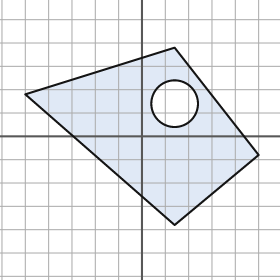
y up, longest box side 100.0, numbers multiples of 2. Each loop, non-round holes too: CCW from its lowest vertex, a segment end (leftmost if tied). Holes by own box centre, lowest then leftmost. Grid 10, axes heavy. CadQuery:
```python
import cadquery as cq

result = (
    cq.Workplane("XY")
    .moveTo(14.0, -38.0)
    .lineTo(50.0, -8.0)
    .lineTo(14.0, 38.0)
    .lineTo(-50.0, 18.0)
    .close()
    .moveTo(14.0, 14.0)
    .circle(10.0)
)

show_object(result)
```